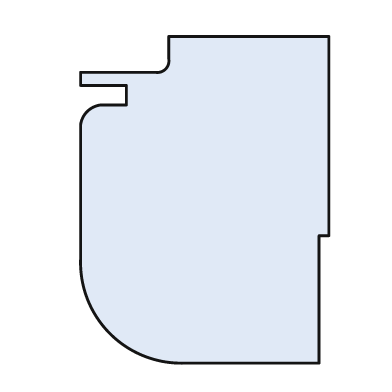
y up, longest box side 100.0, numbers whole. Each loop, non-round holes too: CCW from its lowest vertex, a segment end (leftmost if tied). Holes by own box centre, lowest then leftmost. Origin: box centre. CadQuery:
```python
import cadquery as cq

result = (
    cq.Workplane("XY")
    .moveTo(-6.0, -50.0)
    .lineTo(35.0, -50.0)
    .lineTo(35.0, -11.0)
    .lineTo(38.0, -11.0)
    .lineTo(38.0, 50.0)
    .lineTo(-11.0, 50.0)
    .lineTo(-11.0, 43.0)
    .threePointArc((-12.0, 40.0), (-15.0, 39.0))
    .lineTo(-38.0, 39.0)
    .lineTo(-38.0, 35.0)
    .lineTo(-24.0, 35.0)
    .lineTo(-24.0, 29.0)
    .lineTo(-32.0, 29.0)
    .threePointArc((-36.0, 27.0), (-38.0, 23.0))
    .lineTo(-38.0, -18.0)
    .threePointArc((-29.0, -41.0), (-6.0, -50.0))
    .close()
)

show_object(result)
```